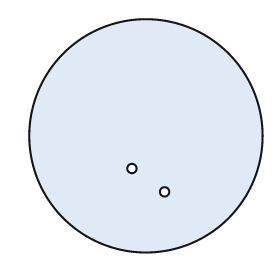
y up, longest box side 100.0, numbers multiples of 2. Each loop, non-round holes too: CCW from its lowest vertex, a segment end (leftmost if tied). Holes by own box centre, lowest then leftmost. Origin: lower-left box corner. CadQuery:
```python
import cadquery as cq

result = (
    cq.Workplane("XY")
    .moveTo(50.0, 50.0)
    .circle(50.0)
    .moveTo(58.0, 26.0)
    .circle(2.0)
    .moveTo(44.0, 36.0)
    .circle(2.0)
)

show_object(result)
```